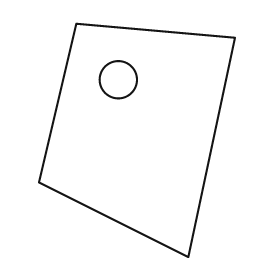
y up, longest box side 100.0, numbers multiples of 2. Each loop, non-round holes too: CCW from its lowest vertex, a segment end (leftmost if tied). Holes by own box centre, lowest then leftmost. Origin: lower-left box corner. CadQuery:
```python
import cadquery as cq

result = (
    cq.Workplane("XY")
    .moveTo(64.0, 0.0)
    .lineTo(84.0, 94.0)
    .lineTo(16.0, 100.0)
    .lineTo(0.0, 32.0)
    .close()
    .moveTo(34.0, 76.0)
    .circle(8.0)
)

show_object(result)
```